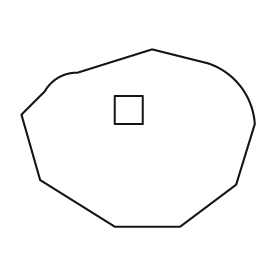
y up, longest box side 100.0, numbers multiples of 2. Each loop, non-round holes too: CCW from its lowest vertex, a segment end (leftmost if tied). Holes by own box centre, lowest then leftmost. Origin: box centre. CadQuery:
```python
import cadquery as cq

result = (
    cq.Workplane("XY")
    .moveTo(-10.0, -38.0)
    .lineTo(18.0, -38.0)
    .lineTo(42.0, -20.0)
    .lineTo(50.0, 6.0)
    .threePointArc((44.0, 22.0), (30.0, 32.0))
    .lineTo(6.0, 38.0)
    .lineTo(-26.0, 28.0)
    .threePointArc((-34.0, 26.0), (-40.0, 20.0))
    .lineTo(-50.0, 10.0)
    .lineTo(-42.0, -18.0)
    .close()
    .moveTo(-10.0, 6.0)
    .lineTo(2.0, 6.0)
    .lineTo(2.0, 18.0)
    .lineTo(-10.0, 18.0)
    .close()
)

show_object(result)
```